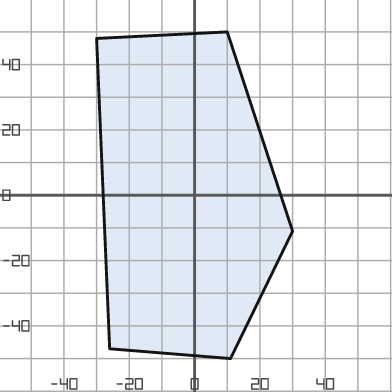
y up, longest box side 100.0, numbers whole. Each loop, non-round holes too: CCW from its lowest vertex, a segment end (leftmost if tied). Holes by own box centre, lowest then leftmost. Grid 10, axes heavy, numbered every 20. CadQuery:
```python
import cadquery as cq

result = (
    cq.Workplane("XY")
    .moveTo(11.0, -50.0)
    .lineTo(30.0, -11.0)
    .lineTo(10.0, 50.0)
    .lineTo(-30.0, 48.0)
    .lineTo(-26.0, -47.0)
    .close()
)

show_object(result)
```